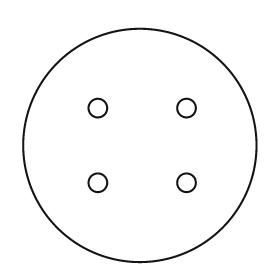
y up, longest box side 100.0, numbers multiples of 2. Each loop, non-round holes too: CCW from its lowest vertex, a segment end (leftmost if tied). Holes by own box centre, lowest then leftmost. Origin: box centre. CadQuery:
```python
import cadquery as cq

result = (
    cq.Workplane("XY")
    .moveTo(0.0, 0.0)
    .circle(50.0)
    .moveTo(-18.0, -16.0)
    .circle(4.0)
    .moveTo(20.0, -16.0)
    .circle(4.0)
    .moveTo(-18.0, 16.0)
    .circle(4.0)
    .moveTo(20.0, 16.0)
    .circle(4.0)
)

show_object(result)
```